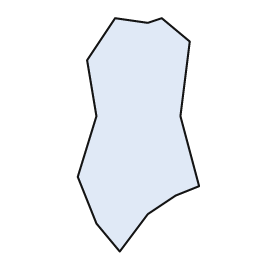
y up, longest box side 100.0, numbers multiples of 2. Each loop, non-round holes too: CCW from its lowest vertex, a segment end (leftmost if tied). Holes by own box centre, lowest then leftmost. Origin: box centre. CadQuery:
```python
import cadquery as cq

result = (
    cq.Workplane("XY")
    .moveTo(-8.0, -50.0)
    .lineTo(4.0, -34.0)
    .lineTo(16.0, -26.0)
    .lineTo(26.0, -22.0)
    .lineTo(18.0, 8.0)
    .lineTo(22.0, 40.0)
    .lineTo(10.0, 50.0)
    .lineTo(4.0, 48.0)
    .lineTo(-10.0, 50.0)
    .lineTo(-22.0, 32.0)
    .lineTo(-18.0, 8.0)
    .lineTo(-26.0, -18.0)
    .lineTo(-18.0, -38.0)
    .close()
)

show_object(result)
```